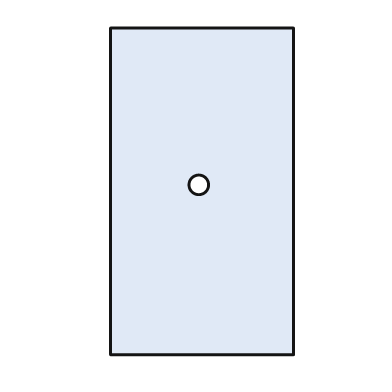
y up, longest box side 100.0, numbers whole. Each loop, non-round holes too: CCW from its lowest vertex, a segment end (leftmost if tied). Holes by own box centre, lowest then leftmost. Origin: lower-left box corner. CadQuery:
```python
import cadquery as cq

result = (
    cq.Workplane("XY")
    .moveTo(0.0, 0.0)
    .lineTo(56.0, 0.0)
    .lineTo(56.0, 100.0)
    .lineTo(0.0, 100.0)
    .close()
    .moveTo(27.0, 52.0)
    .circle(3.0)
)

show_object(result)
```